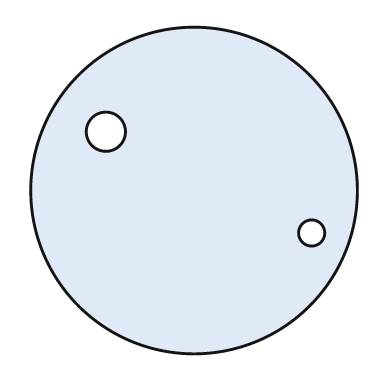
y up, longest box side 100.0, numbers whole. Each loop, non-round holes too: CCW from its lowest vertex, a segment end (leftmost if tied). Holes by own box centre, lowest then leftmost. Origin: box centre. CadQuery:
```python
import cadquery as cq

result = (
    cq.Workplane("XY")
    .moveTo(0.0, 0.0)
    .circle(50.0)
    .moveTo(36.0, -13.0)
    .circle(4.0)
    .moveTo(-27.0, 18.0)
    .circle(6.0)
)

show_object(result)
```